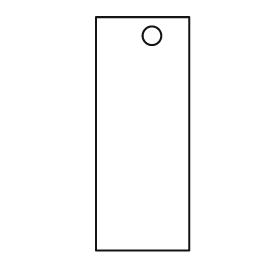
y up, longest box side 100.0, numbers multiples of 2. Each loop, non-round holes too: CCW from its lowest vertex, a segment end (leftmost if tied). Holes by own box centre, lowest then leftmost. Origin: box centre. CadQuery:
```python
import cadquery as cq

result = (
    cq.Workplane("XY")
    .moveTo(-20.0, -50.0)
    .lineTo(20.0, -50.0)
    .lineTo(20.0, 50.0)
    .lineTo(-20.0, 50.0)
    .close()
    .moveTo(4.0, 42.0)
    .circle(4.0)
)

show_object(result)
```